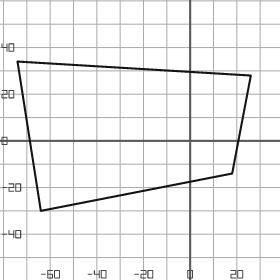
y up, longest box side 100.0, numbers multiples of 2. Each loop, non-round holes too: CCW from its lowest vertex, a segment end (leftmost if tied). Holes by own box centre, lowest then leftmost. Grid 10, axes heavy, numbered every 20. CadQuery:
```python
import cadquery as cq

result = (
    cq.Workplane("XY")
    .moveTo(-64.0, -30.0)
    .lineTo(18.0, -14.0)
    .lineTo(26.0, 28.0)
    .lineTo(-74.0, 34.0)
    .close()
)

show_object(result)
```